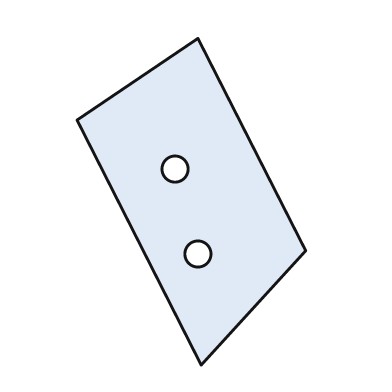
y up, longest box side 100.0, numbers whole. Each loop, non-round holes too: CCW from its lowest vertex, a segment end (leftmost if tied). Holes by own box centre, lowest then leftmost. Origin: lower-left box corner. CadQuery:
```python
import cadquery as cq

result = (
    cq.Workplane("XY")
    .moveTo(38.0, 0.0)
    .lineTo(70.0, 35.0)
    .lineTo(37.0, 100.0)
    .lineTo(0.0, 75.0)
    .close()
    .moveTo(37.0, 34.0)
    .circle(4.0)
    .moveTo(30.0, 60.0)
    .circle(4.0)
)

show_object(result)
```